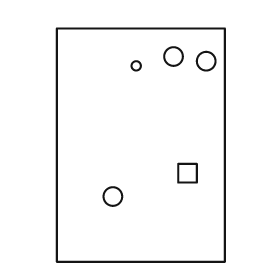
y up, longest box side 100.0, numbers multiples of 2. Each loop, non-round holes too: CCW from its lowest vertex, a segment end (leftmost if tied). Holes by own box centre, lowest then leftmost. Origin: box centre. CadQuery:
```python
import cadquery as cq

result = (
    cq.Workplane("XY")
    .moveTo(-36.0, -50.0)
    .lineTo(36.0, -50.0)
    .lineTo(36.0, 50.0)
    .lineTo(-36.0, 50.0)
    .close()
    .moveTo(-12.0, -22.0)
    .circle(4.0)
    .moveTo(16.0, -16.0)
    .lineTo(24.0, -16.0)
    .lineTo(24.0, -8.0)
    .lineTo(16.0, -8.0)
    .close()
    .moveTo(-2.0, 34.0)
    .circle(2.0)
    .moveTo(28.0, 36.0)
    .circle(4.0)
    .moveTo(14.0, 38.0)
    .circle(4.0)
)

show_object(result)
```